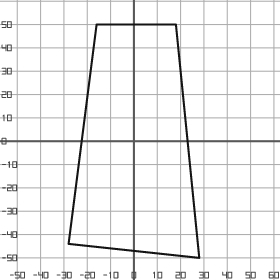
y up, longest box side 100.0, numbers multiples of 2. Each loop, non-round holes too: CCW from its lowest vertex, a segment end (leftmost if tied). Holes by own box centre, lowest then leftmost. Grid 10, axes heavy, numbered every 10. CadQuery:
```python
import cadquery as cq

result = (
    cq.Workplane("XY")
    .moveTo(28.0, -50.0)
    .lineTo(18.0, 50.0)
    .lineTo(-16.0, 50.0)
    .lineTo(-28.0, -44.0)
    .close()
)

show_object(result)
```